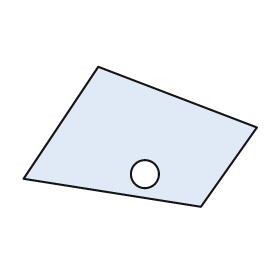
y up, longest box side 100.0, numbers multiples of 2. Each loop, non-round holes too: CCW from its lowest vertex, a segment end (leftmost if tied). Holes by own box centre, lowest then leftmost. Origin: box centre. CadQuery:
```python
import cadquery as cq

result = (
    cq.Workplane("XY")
    .moveTo(26.0, -30.0)
    .lineTo(50.0, 4.0)
    .lineTo(-18.0, 30.0)
    .lineTo(-50.0, -18.0)
    .close()
    .moveTo(2.0, -16.0)
    .circle(6.0)
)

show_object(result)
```